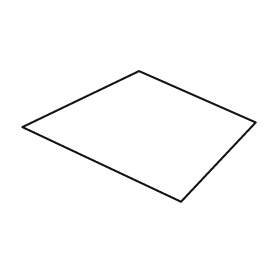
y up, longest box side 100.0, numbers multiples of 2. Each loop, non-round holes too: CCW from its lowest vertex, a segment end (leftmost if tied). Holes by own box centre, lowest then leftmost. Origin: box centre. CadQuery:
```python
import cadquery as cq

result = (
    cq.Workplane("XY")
    .moveTo(18.0, -28.0)
    .lineTo(50.0, 6.0)
    .lineTo(0.0, 28.0)
    .lineTo(-50.0, 4.0)
    .close()
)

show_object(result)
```